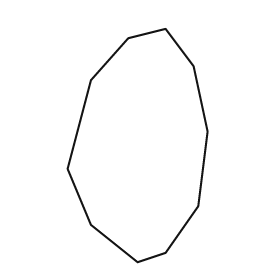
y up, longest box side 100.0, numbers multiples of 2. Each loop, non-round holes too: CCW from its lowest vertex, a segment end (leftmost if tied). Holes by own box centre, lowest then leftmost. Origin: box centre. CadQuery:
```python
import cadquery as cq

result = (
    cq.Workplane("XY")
    .moveTo(0.0, -50.0)
    .lineTo(12.0, -46.0)
    .lineTo(26.0, -26.0)
    .lineTo(30.0, 6.0)
    .lineTo(24.0, 34.0)
    .lineTo(12.0, 50.0)
    .lineTo(-4.0, 46.0)
    .lineTo(-20.0, 28.0)
    .lineTo(-30.0, -10.0)
    .lineTo(-20.0, -34.0)
    .close()
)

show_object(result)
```